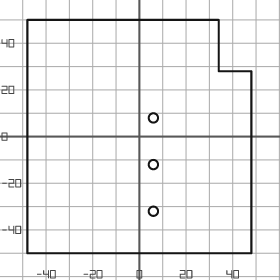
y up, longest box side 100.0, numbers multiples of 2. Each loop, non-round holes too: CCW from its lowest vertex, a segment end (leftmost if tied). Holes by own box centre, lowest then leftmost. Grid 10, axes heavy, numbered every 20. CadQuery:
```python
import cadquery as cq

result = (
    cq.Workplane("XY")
    .moveTo(-48.0, -50.0)
    .lineTo(48.0, -50.0)
    .lineTo(48.0, 28.0)
    .lineTo(34.0, 28.0)
    .lineTo(34.0, 50.0)
    .lineTo(-48.0, 50.0)
    .close()
    .moveTo(6.0, -32.0)
    .circle(2.0)
    .moveTo(6.0, -12.0)
    .circle(2.0)
    .moveTo(6.0, 8.0)
    .circle(2.0)
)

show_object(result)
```